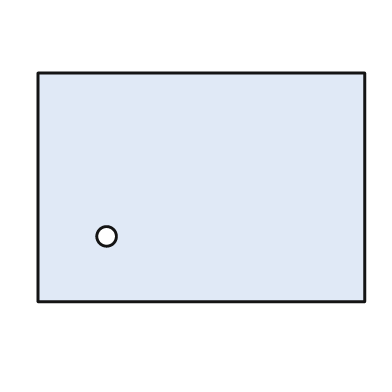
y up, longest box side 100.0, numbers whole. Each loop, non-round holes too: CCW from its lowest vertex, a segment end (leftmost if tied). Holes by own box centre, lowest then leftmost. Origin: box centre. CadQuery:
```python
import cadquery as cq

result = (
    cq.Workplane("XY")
    .moveTo(-50.0, -35.0)
    .lineTo(50.0, -35.0)
    .lineTo(50.0, 35.0)
    .lineTo(-50.0, 35.0)
    .close()
    .moveTo(-29.0, -15.0)
    .circle(3.0)
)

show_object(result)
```